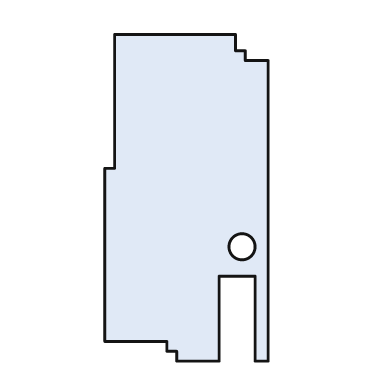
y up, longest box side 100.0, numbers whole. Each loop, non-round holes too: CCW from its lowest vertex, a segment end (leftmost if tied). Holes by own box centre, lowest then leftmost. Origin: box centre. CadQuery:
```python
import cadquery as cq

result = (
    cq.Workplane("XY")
    .moveTo(-3.0, -50.0)
    .lineTo(10.0, -50.0)
    .lineTo(10.0, -24.0)
    .lineTo(21.0, -24.0)
    .lineTo(21.0, -50.0)
    .lineTo(25.0, -50.0)
    .lineTo(25.0, 42.0)
    .lineTo(18.0, 42.0)
    .lineTo(18.0, 45.0)
    .lineTo(15.0, 45.0)
    .lineTo(15.0, 50.0)
    .lineTo(-22.0, 50.0)
    .lineTo(-22.0, 9.0)
    .lineTo(-25.0, 9.0)
    .lineTo(-25.0, -44.0)
    .lineTo(-6.0, -44.0)
    .lineTo(-6.0, -47.0)
    .lineTo(-3.0, -47.0)
    .close()
    .moveTo(17.0, -15.0)
    .circle(4.0)
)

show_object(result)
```